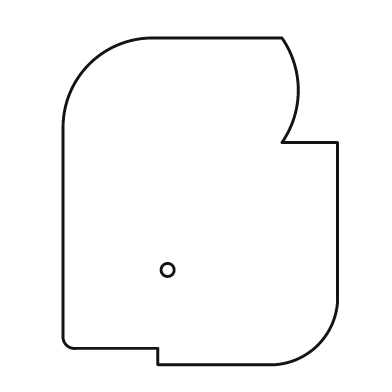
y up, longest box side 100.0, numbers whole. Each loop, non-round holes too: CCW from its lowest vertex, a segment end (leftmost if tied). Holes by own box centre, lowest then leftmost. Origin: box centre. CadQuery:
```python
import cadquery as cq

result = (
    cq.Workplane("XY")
    .moveTo(-13.0, -50.0)
    .lineTo(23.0, -50.0)
    .threePointArc((36.0, -44.0), (42.0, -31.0))
    .lineTo(42.0, 18.0)
    .lineTo(25.0, 18.0)
    .threePointArc((30.0, 34.0), (25.0, 50.0))
    .lineTo(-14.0, 50.0)
    .threePointArc((-34.0, 42.0), (-42.0, 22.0))
    .lineTo(-42.0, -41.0)
    .threePointArc((-41.0, -44.0), (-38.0, -45.0))
    .lineTo(-13.0, -45.0)
    .close()
    .moveTo(-10.0, -21.0)
    .circle(2.0)
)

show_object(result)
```